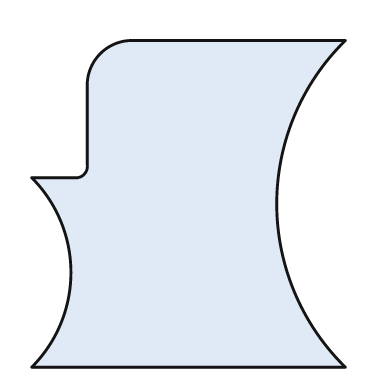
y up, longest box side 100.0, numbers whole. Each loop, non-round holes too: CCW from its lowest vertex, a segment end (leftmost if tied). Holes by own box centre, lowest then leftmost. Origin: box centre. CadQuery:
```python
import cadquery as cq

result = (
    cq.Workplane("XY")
    .moveTo(-48.0, -50.0)
    .lineTo(48.0, -50.0)
    .threePointArc((27.0, 0.0), (48.0, 50.0))
    .lineTo(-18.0, 50.0)
    .threePointArc((-27.0, 46.0), (-31.0, 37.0))
    .lineTo(-31.0, 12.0)
    .threePointArc((-32.0, 9.0), (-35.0, 8.0))
    .lineTo(-48.0, 8.0)
    .threePointArc((-36.0, -21.0), (-48.0, -50.0))
    .close()
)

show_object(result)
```